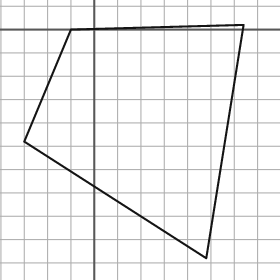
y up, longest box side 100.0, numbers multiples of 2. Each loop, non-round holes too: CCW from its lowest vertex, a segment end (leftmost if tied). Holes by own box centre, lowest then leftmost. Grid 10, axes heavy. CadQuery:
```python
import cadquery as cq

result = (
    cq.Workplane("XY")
    .moveTo(48.0, -98.0)
    .lineTo(64.0, 2.0)
    .lineTo(-10.0, 0.0)
    .lineTo(-30.0, -48.0)
    .close()
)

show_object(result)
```